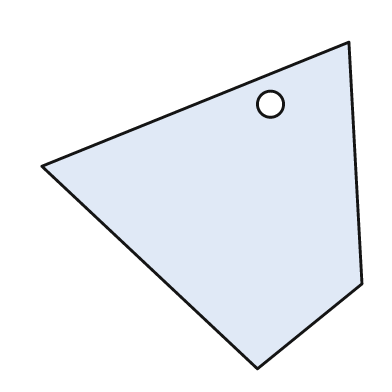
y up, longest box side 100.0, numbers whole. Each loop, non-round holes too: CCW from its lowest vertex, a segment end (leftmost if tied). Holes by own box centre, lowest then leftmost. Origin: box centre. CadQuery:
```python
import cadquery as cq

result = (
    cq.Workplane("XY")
    .moveTo(17.0, -50.0)
    .lineTo(49.0, -24.0)
    .lineTo(45.0, 50.0)
    .lineTo(-49.0, 12.0)
    .close()
    .moveTo(21.0, 31.0)
    .circle(4.0)
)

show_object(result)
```